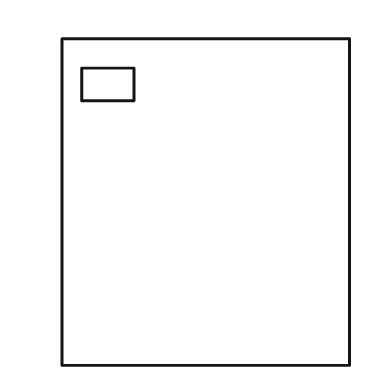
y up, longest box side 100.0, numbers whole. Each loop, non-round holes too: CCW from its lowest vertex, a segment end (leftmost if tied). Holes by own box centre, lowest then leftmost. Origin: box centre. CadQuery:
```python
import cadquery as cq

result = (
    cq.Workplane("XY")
    .moveTo(-44.0, -50.0)
    .lineTo(44.0, -50.0)
    .lineTo(44.0, 50.0)
    .lineTo(-44.0, 50.0)
    .close()
    .moveTo(-38.0, 31.0)
    .lineTo(-22.0, 31.0)
    .lineTo(-22.0, 41.0)
    .lineTo(-38.0, 41.0)
    .close()
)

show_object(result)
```